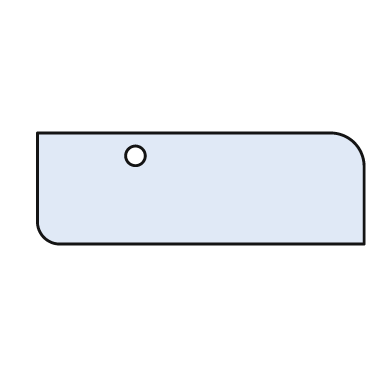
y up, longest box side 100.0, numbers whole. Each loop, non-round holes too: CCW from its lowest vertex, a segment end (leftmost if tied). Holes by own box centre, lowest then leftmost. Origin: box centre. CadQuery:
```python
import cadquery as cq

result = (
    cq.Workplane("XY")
    .moveTo(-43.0, -17.0)
    .lineTo(50.0, -17.0)
    .lineTo(50.0, 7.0)
    .threePointArc((47.0, 14.0), (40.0, 17.0))
    .lineTo(-50.0, 17.0)
    .lineTo(-50.0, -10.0)
    .threePointArc((-48.0, -15.0), (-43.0, -17.0))
    .close()
    .moveTo(-20.0, 10.0)
    .circle(3.0)
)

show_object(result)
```